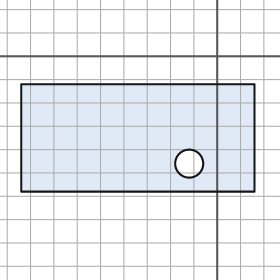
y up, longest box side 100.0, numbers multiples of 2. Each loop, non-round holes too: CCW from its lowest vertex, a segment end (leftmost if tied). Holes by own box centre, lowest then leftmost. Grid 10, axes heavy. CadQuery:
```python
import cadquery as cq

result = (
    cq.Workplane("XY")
    .moveTo(-84.0, -58.0)
    .lineTo(16.0, -58.0)
    .lineTo(16.0, -12.0)
    .lineTo(-84.0, -12.0)
    .close()
    .moveTo(-12.0, -46.0)
    .circle(6.0)
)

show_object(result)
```